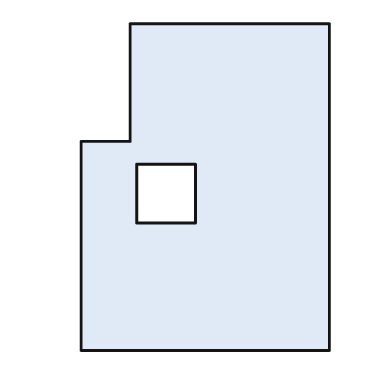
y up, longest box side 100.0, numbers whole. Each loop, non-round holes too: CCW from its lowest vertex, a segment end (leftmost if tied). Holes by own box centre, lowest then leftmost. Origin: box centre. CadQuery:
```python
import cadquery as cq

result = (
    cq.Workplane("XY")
    .moveTo(-38.0, -50.0)
    .lineTo(38.0, -50.0)
    .lineTo(38.0, 50.0)
    .lineTo(-23.0, 50.0)
    .lineTo(-23.0, 14.0)
    .lineTo(-38.0, 14.0)
    .close()
    .moveTo(-21.0, -11.0)
    .lineTo(-3.0, -11.0)
    .lineTo(-3.0, 7.0)
    .lineTo(-21.0, 7.0)
    .close()
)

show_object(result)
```